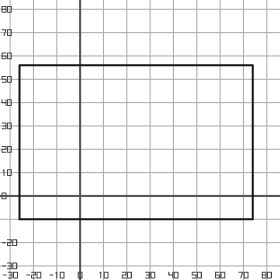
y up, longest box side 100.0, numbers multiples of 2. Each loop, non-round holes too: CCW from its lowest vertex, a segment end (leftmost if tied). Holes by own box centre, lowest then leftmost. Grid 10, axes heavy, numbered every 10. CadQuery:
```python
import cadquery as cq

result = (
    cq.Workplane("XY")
    .moveTo(-26.0, -10.0)
    .lineTo(74.0, -10.0)
    .lineTo(74.0, 56.0)
    .lineTo(-26.0, 56.0)
    .close()
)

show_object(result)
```